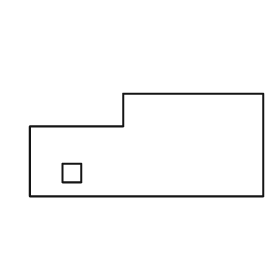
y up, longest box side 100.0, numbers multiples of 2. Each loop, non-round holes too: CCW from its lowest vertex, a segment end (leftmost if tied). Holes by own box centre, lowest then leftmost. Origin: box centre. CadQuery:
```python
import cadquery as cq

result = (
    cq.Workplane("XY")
    .moveTo(-50.0, -22.0)
    .lineTo(50.0, -22.0)
    .lineTo(50.0, 22.0)
    .lineTo(-10.0, 22.0)
    .lineTo(-10.0, 8.0)
    .lineTo(-50.0, 8.0)
    .close()
    .moveTo(-36.0, -16.0)
    .lineTo(-28.0, -16.0)
    .lineTo(-28.0, -8.0)
    .lineTo(-36.0, -8.0)
    .close()
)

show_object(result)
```